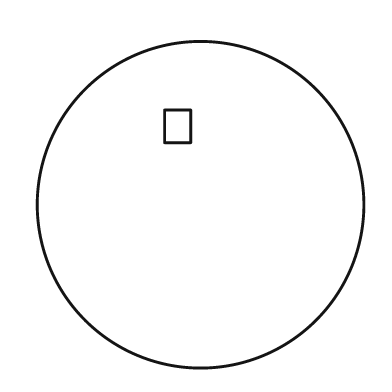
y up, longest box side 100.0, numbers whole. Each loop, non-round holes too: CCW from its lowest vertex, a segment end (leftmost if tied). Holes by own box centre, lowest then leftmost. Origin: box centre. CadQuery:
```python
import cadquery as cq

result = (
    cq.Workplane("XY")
    .moveTo(0.0, 0.0)
    .circle(50.0)
    .moveTo(-11.0, 19.0)
    .lineTo(-3.0, 19.0)
    .lineTo(-3.0, 29.0)
    .lineTo(-11.0, 29.0)
    .close()
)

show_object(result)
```